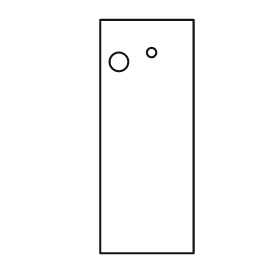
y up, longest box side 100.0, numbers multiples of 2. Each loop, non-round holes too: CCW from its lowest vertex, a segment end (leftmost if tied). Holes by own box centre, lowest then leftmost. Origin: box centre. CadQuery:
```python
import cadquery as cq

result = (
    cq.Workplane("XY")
    .moveTo(-20.0, -50.0)
    .lineTo(20.0, -50.0)
    .lineTo(20.0, 50.0)
    .lineTo(-20.0, 50.0)
    .close()
    .moveTo(-12.0, 32.0)
    .circle(4.0)
    .moveTo(2.0, 36.0)
    .circle(2.0)
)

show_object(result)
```